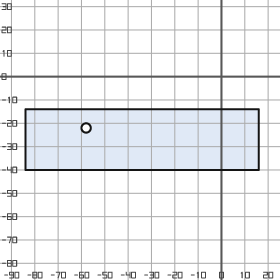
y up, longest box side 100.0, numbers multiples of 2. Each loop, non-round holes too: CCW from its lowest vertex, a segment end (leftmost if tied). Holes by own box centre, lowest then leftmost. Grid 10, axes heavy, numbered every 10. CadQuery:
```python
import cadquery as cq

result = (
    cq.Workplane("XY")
    .moveTo(-84.0, -40.0)
    .lineTo(16.0, -40.0)
    .lineTo(16.0, -14.0)
    .lineTo(-84.0, -14.0)
    .close()
    .moveTo(-58.0, -22.0)
    .circle(2.0)
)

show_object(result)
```